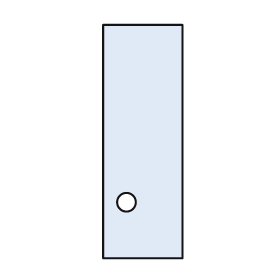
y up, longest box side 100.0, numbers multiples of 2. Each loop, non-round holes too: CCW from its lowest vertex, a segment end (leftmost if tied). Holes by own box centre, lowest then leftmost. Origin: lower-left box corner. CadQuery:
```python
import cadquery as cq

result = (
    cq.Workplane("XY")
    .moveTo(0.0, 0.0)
    .lineTo(34.0, 0.0)
    .lineTo(34.0, 100.0)
    .lineTo(0.0, 100.0)
    .close()
    .moveTo(10.0, 24.0)
    .circle(4.0)
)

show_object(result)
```